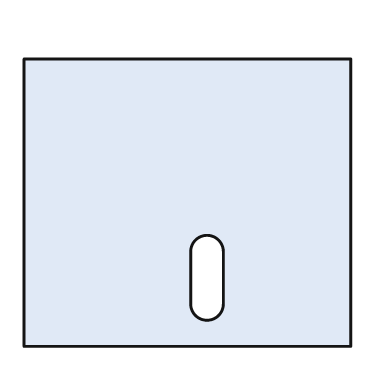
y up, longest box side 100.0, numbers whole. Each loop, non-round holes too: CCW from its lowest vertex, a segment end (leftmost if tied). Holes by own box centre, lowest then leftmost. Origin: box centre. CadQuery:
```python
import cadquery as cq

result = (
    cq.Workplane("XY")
    .moveTo(-50.0, -44.0)
    .lineTo(50.0, -44.0)
    .lineTo(50.0, 44.0)
    .lineTo(-50.0, 44.0)
    .close()
    .moveTo(1.0, -31.0)
    .threePointArc((6.0, -36.0), (11.0, -31.0))
    .lineTo(11.0, -15.0)
    .threePointArc((6.0, -10.0), (1.0, -15.0))
    .close()
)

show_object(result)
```